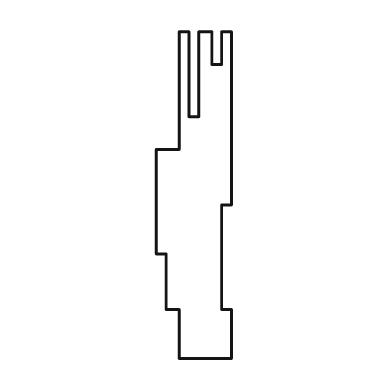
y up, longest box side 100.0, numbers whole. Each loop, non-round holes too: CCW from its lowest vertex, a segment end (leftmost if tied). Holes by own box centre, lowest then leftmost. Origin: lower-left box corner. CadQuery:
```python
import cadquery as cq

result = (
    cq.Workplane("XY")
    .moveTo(7.0, 0.0)
    .lineTo(23.0, 0.0)
    .lineTo(23.0, 15.0)
    .lineTo(20.0, 15.0)
    .lineTo(20.0, 47.0)
    .lineTo(23.0, 47.0)
    .lineTo(23.0, 100.0)
    .lineTo(20.0, 100.0)
    .lineTo(20.0, 90.0)
    .lineTo(17.0, 90.0)
    .lineTo(17.0, 100.0)
    .lineTo(13.0, 100.0)
    .lineTo(13.0, 74.0)
    .lineTo(10.0, 74.0)
    .lineTo(10.0, 100.0)
    .lineTo(7.0, 100.0)
    .lineTo(7.0, 64.0)
    .lineTo(0.0, 64.0)
    .lineTo(0.0, 32.0)
    .lineTo(3.0, 32.0)
    .lineTo(3.0, 15.0)
    .lineTo(7.0, 15.0)
    .close()
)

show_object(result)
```